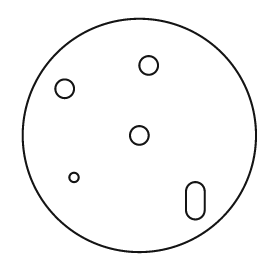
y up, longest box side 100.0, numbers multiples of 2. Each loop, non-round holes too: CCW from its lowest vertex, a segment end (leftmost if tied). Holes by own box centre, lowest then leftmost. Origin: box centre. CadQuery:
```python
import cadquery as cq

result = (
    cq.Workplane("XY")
    .moveTo(0.0, 0.0)
    .circle(50.0)
    .moveTo(20.0, -32.0)
    .threePointArc((24.0, -36.0), (28.0, -32.0))
    .lineTo(28.0, -24.0)
    .threePointArc((24.0, -20.0), (20.0, -24.0))
    .close()
    .moveTo(-28.0, -18.0)
    .circle(2.0)
    .moveTo(0.0, 0.0)
    .circle(4.0)
    .moveTo(-32.0, 20.0)
    .circle(4.0)
    .moveTo(4.0, 30.0)
    .circle(4.0)
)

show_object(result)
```